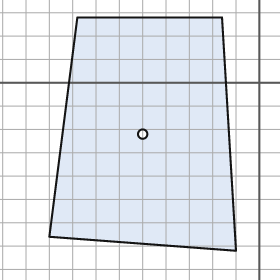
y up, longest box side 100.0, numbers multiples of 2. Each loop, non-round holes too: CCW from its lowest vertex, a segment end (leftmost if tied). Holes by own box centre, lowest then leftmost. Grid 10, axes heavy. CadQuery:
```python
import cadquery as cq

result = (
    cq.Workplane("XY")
    .moveTo(-10.0, -72.0)
    .lineTo(-16.0, 28.0)
    .lineTo(-78.0, 28.0)
    .lineTo(-90.0, -66.0)
    .close()
    .moveTo(-50.0, -22.0)
    .circle(2.0)
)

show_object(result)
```